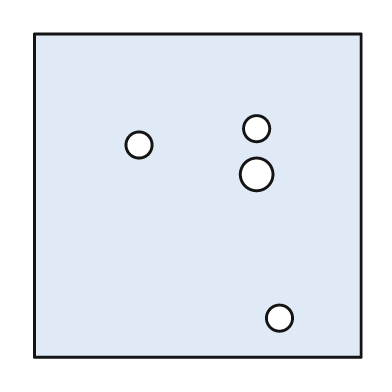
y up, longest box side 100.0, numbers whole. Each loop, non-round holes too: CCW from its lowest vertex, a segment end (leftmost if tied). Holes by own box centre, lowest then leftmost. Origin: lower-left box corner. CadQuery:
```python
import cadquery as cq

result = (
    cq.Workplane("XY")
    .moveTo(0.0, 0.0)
    .lineTo(100.0, 0.0)
    .lineTo(100.0, 99.0)
    .lineTo(0.0, 99.0)
    .close()
    .moveTo(75.0, 12.0)
    .circle(4.0)
    .moveTo(68.0, 56.0)
    .circle(5.0)
    .moveTo(32.0, 65.0)
    .circle(4.0)
    .moveTo(68.0, 70.0)
    .circle(4.0)
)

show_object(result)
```